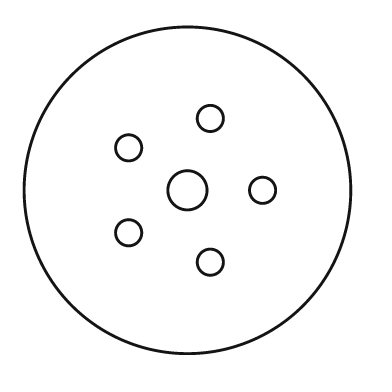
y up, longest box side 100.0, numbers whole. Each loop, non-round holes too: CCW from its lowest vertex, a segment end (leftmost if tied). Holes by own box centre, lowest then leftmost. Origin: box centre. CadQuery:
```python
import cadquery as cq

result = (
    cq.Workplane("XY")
    .moveTo(0.0, 0.0)
    .circle(50.0)
    .moveTo(7.0, -22.0)
    .circle(4.0)
    .moveTo(-18.0, -13.0)
    .circle(4.0)
    .moveTo(0.0, 0.0)
    .circle(6.0)
    .moveTo(23.0, 0.0)
    .circle(4.0)
    .moveTo(-18.0, 13.0)
    .circle(4.0)
    .moveTo(7.0, 22.0)
    .circle(4.0)
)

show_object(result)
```